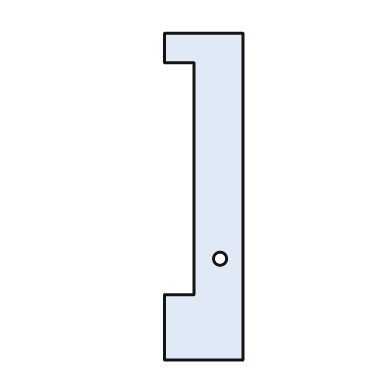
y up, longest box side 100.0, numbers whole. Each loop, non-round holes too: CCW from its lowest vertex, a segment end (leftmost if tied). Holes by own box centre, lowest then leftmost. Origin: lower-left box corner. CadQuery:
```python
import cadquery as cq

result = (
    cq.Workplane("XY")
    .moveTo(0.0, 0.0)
    .lineTo(24.0, 0.0)
    .lineTo(24.0, 100.0)
    .lineTo(0.0, 100.0)
    .lineTo(0.0, 91.0)
    .lineTo(9.0, 91.0)
    .lineTo(9.0, 20.0)
    .lineTo(0.0, 20.0)
    .close()
    .moveTo(17.0, 31.0)
    .circle(2.0)
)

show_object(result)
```